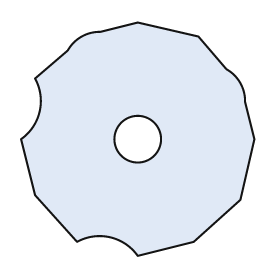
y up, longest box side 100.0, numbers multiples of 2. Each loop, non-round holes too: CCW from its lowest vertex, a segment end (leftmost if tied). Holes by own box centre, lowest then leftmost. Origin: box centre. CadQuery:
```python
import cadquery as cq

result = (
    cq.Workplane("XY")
    .moveTo(0.0, -50.0)
    .lineTo(24.0, -44.0)
    .lineTo(44.0, -26.0)
    .lineTo(50.0, 0.0)
    .lineTo(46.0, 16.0)
    .threePointArc((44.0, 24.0), (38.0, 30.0))
    .lineTo(26.0, 44.0)
    .lineTo(0.0, 50.0)
    .lineTo(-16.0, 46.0)
    .threePointArc((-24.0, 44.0), (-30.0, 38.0))
    .lineTo(-44.0, 26.0)
    .threePointArc((-42.0, 12.0), (-50.0, 0.0))
    .lineTo(-44.0, -24.0)
    .lineTo(-26.0, -44.0)
    .threePointArc((-12.0, -42.0), (0.0, -50.0))
    .close()
    .moveTo(0.0, 0.0)
    .circle(10.0)
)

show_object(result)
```